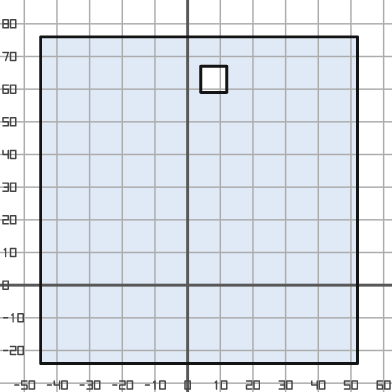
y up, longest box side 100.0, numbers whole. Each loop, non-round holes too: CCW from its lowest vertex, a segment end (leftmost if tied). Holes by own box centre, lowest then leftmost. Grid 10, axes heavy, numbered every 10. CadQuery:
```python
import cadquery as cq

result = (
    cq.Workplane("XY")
    .moveTo(-45.0, -24.0)
    .lineTo(52.0, -24.0)
    .lineTo(52.0, 76.0)
    .lineTo(-45.0, 76.0)
    .close()
    .moveTo(4.0, 59.0)
    .lineTo(12.0, 59.0)
    .lineTo(12.0, 67.0)
    .lineTo(4.0, 67.0)
    .close()
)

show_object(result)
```